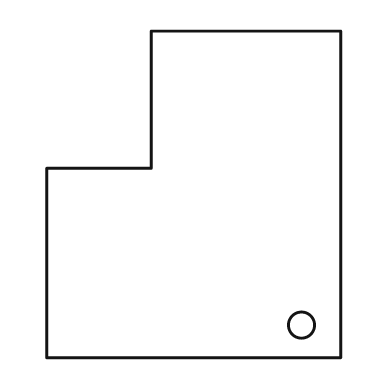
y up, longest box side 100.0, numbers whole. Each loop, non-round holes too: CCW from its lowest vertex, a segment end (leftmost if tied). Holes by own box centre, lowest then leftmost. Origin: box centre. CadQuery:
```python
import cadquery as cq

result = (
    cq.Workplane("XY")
    .moveTo(-45.0, -50.0)
    .lineTo(45.0, -50.0)
    .lineTo(45.0, 50.0)
    .lineTo(-13.0, 50.0)
    .lineTo(-13.0, 8.0)
    .lineTo(-45.0, 8.0)
    .close()
    .moveTo(33.0, -40.0)
    .circle(4.0)
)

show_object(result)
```